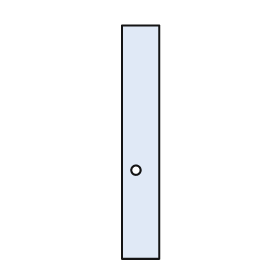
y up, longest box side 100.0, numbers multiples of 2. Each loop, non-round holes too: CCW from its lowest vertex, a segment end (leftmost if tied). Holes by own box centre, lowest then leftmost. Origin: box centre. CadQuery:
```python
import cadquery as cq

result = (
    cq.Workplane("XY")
    .moveTo(-8.0, -50.0)
    .lineTo(8.0, -50.0)
    .lineTo(8.0, 50.0)
    .lineTo(-8.0, 50.0)
    .close()
    .moveTo(-2.0, -12.0)
    .circle(2.0)
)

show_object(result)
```